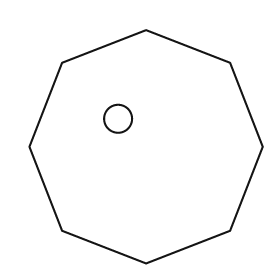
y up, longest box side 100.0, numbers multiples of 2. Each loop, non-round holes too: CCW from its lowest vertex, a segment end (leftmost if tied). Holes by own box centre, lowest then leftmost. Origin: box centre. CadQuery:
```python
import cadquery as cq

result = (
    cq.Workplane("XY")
    .moveTo(0.0, -50.0)
    .lineTo(36.0, -36.0)
    .lineTo(50.0, 0.0)
    .lineTo(36.0, 36.0)
    .lineTo(0.0, 50.0)
    .lineTo(-36.0, 36.0)
    .lineTo(-50.0, 0.0)
    .lineTo(-36.0, -36.0)
    .close()
    .moveTo(-12.0, 12.0)
    .circle(6.0)
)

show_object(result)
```